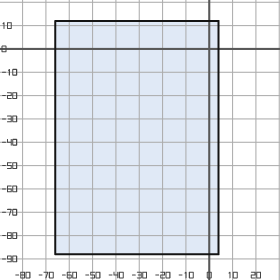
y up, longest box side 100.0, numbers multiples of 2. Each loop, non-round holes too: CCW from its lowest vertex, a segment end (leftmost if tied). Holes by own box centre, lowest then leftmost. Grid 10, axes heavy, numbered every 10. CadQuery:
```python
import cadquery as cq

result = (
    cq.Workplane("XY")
    .moveTo(-66.0, -88.0)
    .lineTo(4.0, -88.0)
    .lineTo(4.0, 12.0)
    .lineTo(-66.0, 12.0)
    .close()
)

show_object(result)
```